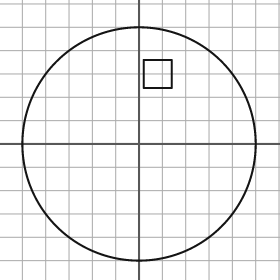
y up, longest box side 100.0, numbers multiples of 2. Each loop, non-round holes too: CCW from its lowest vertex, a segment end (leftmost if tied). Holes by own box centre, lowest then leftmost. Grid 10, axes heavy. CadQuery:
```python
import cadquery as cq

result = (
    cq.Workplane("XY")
    .moveTo(0.0, 0.0)
    .circle(50.0)
    .moveTo(2.0, 24.0)
    .lineTo(14.0, 24.0)
    .lineTo(14.0, 36.0)
    .lineTo(2.0, 36.0)
    .close()
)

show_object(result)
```